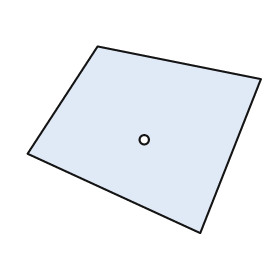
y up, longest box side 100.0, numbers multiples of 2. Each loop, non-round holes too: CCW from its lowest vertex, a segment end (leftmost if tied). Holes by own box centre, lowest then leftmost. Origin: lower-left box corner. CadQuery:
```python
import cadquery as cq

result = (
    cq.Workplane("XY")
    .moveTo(74.0, 0.0)
    .lineTo(100.0, 66.0)
    .lineTo(30.0, 80.0)
    .lineTo(0.0, 34.0)
    .close()
    .moveTo(50.0, 40.0)
    .circle(2.0)
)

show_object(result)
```